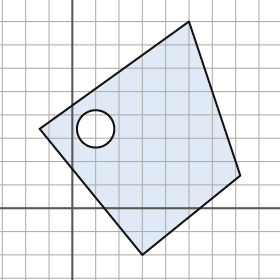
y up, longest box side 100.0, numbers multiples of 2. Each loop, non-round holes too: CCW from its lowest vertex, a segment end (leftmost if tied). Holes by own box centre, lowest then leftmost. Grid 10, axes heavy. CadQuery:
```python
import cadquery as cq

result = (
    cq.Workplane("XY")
    .moveTo(30.0, -20.0)
    .lineTo(72.0, 14.0)
    .lineTo(50.0, 80.0)
    .lineTo(-14.0, 34.0)
    .close()
    .moveTo(10.0, 34.0)
    .circle(8.0)
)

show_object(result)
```